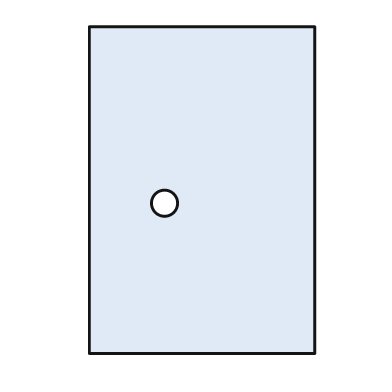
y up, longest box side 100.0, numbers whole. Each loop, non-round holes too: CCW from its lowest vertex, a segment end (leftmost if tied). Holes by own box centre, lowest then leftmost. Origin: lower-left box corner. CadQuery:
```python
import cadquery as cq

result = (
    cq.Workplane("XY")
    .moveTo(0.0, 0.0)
    .lineTo(69.0, 0.0)
    .lineTo(69.0, 100.0)
    .lineTo(0.0, 100.0)
    .close()
    .moveTo(23.0, 46.0)
    .circle(4.0)
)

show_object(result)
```